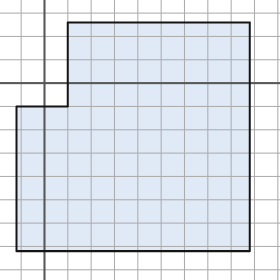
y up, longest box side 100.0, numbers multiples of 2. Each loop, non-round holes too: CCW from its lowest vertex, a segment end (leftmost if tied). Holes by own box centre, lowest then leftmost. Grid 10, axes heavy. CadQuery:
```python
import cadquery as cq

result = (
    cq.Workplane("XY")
    .moveTo(-12.0, -72.0)
    .lineTo(88.0, -72.0)
    .lineTo(88.0, 26.0)
    .lineTo(10.0, 26.0)
    .lineTo(10.0, -10.0)
    .lineTo(-12.0, -10.0)
    .close()
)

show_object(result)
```